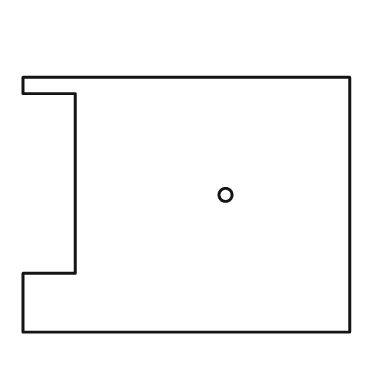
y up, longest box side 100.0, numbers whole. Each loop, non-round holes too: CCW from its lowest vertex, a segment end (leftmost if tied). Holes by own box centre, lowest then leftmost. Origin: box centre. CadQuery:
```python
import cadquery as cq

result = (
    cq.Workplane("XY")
    .moveTo(-50.0, -39.0)
    .lineTo(50.0, -39.0)
    .lineTo(50.0, 39.0)
    .lineTo(-50.0, 39.0)
    .lineTo(-50.0, 34.0)
    .lineTo(-34.0, 34.0)
    .lineTo(-34.0, -21.0)
    .lineTo(-50.0, -21.0)
    .close()
    .moveTo(12.0, 3.0)
    .circle(2.0)
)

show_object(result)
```